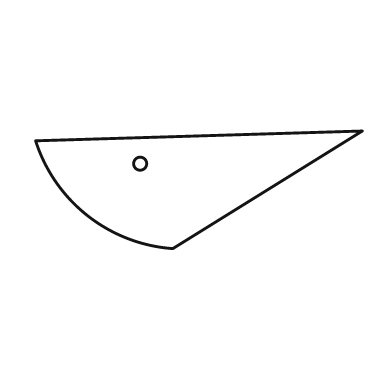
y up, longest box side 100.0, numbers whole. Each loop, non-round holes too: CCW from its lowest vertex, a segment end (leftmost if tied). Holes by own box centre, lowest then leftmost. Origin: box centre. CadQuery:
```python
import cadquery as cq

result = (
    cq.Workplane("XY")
    .moveTo(-8.0, -18.0)
    .lineTo(50.0, 18.0)
    .lineTo(-50.0, 15.0)
    .threePointArc((-34.0, -8.0), (-8.0, -18.0))
    .close()
    .moveTo(-18.0, 8.0)
    .circle(2.0)
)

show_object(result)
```